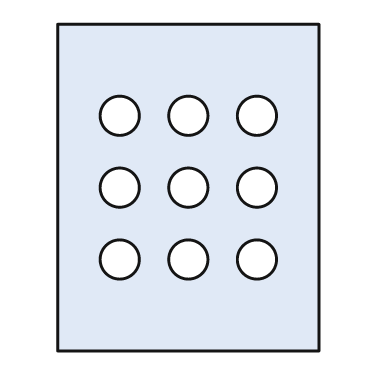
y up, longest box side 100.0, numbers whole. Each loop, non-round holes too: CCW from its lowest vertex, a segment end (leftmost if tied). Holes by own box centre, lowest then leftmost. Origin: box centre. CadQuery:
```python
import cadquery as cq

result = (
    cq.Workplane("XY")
    .moveTo(-40.0, -50.0)
    .lineTo(40.0, -50.0)
    .lineTo(40.0, 50.0)
    .lineTo(-40.0, 50.0)
    .close()
    .moveTo(-21.0, -22.0)
    .circle(6.0)
    .moveTo(0.0, -22.0)
    .circle(6.0)
    .moveTo(21.0, -22.0)
    .circle(6.0)
    .moveTo(-21.0, 0.0)
    .circle(6.0)
    .moveTo(0.0, 0.0)
    .circle(6.0)
    .moveTo(21.0, 0.0)
    .circle(6.0)
    .moveTo(-21.0, 22.0)
    .circle(6.0)
    .moveTo(0.0, 22.0)
    .circle(6.0)
    .moveTo(21.0, 22.0)
    .circle(6.0)
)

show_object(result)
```